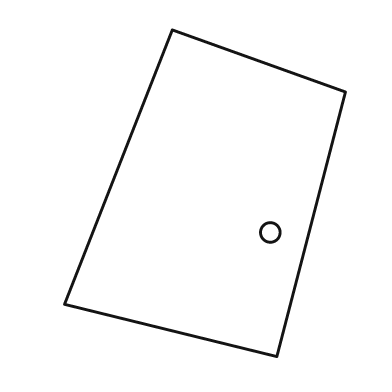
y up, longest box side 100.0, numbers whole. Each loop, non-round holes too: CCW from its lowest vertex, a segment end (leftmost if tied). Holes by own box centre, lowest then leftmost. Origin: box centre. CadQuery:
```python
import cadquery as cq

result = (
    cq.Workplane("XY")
    .moveTo(22.0, -50.0)
    .lineTo(43.0, 31.0)
    .lineTo(-10.0, 50.0)
    .lineTo(-43.0, -34.0)
    .close()
    .moveTo(20.0, -12.0)
    .circle(3.0)
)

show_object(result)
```